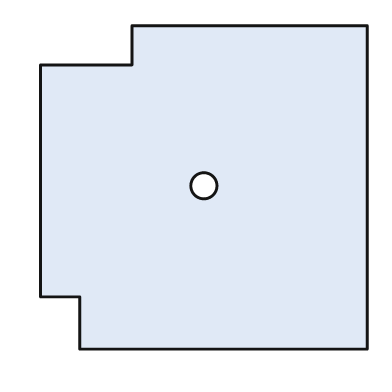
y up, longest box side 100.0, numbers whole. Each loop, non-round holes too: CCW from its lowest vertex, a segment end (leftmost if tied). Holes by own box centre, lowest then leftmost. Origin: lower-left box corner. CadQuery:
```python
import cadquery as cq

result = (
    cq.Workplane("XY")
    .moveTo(12.0, 0.0)
    .lineTo(100.0, 0.0)
    .lineTo(100.0, 99.0)
    .lineTo(28.0, 99.0)
    .lineTo(28.0, 87.0)
    .lineTo(0.0, 87.0)
    .lineTo(0.0, 16.0)
    .lineTo(12.0, 16.0)
    .close()
    .moveTo(50.0, 50.0)
    .circle(4.0)
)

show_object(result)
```